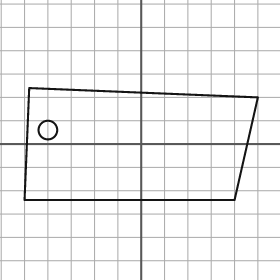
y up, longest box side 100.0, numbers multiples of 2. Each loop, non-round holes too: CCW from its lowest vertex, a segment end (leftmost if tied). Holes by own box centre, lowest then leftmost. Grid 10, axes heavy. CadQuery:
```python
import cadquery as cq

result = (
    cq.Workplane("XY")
    .moveTo(-50.0, -24.0)
    .lineTo(40.0, -24.0)
    .lineTo(50.0, 20.0)
    .lineTo(-48.0, 24.0)
    .close()
    .moveTo(-40.0, 6.0)
    .circle(4.0)
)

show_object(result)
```